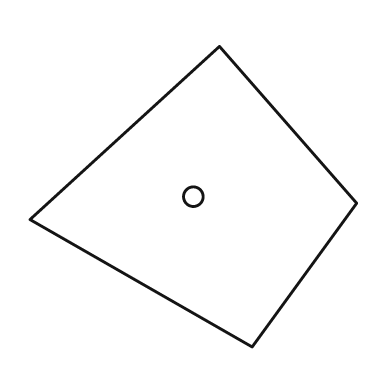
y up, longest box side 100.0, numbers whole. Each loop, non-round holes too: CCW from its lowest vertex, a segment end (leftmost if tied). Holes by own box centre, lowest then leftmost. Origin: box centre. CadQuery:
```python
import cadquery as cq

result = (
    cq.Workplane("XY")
    .moveTo(18.0, -46.0)
    .lineTo(50.0, -2.0)
    .lineTo(8.0, 46.0)
    .lineTo(-50.0, -7.0)
    .close()
    .moveTo(0.0, 0.0)
    .circle(3.0)
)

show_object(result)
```